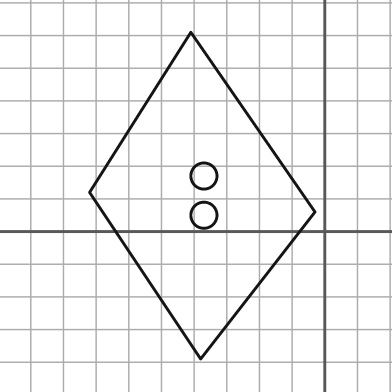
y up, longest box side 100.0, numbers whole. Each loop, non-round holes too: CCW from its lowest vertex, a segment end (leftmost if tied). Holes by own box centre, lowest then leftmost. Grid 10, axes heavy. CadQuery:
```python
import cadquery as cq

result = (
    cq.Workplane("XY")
    .moveTo(-38.0, -39.0)
    .lineTo(-3.0, 6.0)
    .lineTo(-41.0, 61.0)
    .lineTo(-72.0, 12.0)
    .close()
    .moveTo(-37.0, 5.0)
    .circle(4.0)
    .moveTo(-37.0, 17.0)
    .circle(4.0)
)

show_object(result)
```